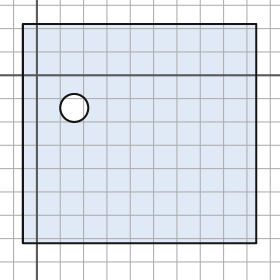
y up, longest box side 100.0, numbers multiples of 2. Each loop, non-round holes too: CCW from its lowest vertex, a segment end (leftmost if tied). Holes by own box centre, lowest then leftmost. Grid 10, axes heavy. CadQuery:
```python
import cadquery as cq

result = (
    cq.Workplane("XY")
    .moveTo(-6.0, -72.0)
    .lineTo(94.0, -72.0)
    .lineTo(94.0, 22.0)
    .lineTo(-6.0, 22.0)
    .close()
    .moveTo(16.0, -14.0)
    .circle(6.0)
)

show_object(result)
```